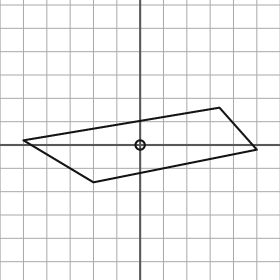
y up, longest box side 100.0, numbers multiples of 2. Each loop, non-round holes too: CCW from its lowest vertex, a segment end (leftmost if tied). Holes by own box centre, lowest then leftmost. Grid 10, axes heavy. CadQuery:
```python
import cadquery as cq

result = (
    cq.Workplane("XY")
    .moveTo(-20.0, -16.0)
    .lineTo(50.0, -2.0)
    .lineTo(34.0, 16.0)
    .lineTo(-50.0, 2.0)
    .close()
    .moveTo(0.0, 0.0)
    .circle(2.0)
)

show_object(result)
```